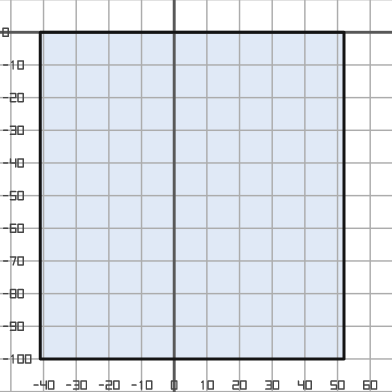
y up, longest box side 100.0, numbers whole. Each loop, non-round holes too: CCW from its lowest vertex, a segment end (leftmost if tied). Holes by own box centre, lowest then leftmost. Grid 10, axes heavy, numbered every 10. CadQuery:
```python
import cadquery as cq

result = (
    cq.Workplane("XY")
    .moveTo(-41.0, -100.0)
    .lineTo(52.0, -100.0)
    .lineTo(52.0, 0.0)
    .lineTo(-41.0, 0.0)
    .close()
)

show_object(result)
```